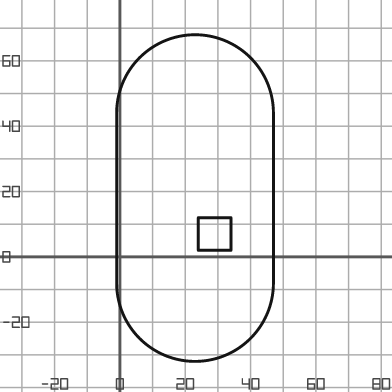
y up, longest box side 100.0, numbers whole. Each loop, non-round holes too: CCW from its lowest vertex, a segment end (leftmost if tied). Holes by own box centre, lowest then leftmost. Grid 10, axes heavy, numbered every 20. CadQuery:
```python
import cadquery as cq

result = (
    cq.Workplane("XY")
    .moveTo(-1.0, -8.0)
    .threePointArc((23.0, -32.0), (47.0, -8.0))
    .lineTo(47.0, 44.0)
    .threePointArc((23.0, 68.0), (-1.0, 44.0))
    .close()
    .moveTo(24.0, 2.0)
    .lineTo(34.0, 2.0)
    .lineTo(34.0, 12.0)
    .lineTo(24.0, 12.0)
    .close()
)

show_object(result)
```